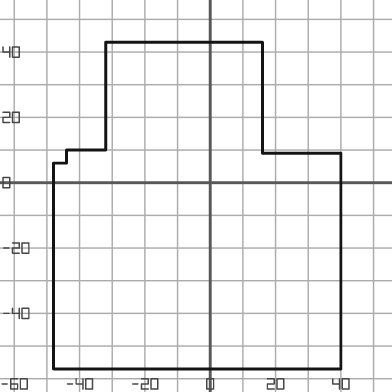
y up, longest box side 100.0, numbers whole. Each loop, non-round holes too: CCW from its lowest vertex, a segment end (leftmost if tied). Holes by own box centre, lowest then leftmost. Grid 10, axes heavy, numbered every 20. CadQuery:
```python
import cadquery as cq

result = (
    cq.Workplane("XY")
    .moveTo(-48.0, -57.0)
    .lineTo(40.0, -57.0)
    .lineTo(40.0, 9.0)
    .lineTo(16.0, 9.0)
    .lineTo(16.0, 43.0)
    .lineTo(-32.0, 43.0)
    .lineTo(-32.0, 10.0)
    .lineTo(-44.0, 10.0)
    .lineTo(-44.0, 6.0)
    .lineTo(-48.0, 6.0)
    .close()
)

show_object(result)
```